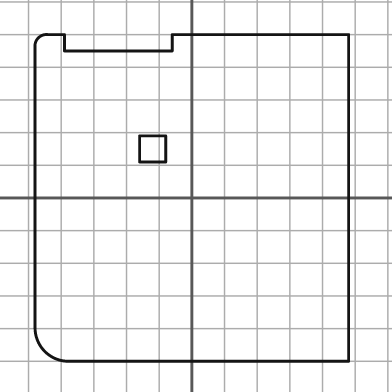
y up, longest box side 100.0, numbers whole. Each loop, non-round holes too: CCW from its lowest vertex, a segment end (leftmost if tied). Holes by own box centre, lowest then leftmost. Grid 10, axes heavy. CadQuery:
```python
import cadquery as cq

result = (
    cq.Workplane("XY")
    .moveTo(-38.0, -50.0)
    .lineTo(48.0, -50.0)
    .lineTo(48.0, 50.0)
    .lineTo(-6.0, 50.0)
    .lineTo(-6.0, 45.0)
    .lineTo(-39.0, 45.0)
    .lineTo(-39.0, 50.0)
    .lineTo(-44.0, 50.0)
    .threePointArc((-47.0, 49.0), (-48.0, 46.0))
    .lineTo(-48.0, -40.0)
    .threePointArc((-45.0, -47.0), (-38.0, -50.0))
    .close()
    .moveTo(-16.0, 11.0)
    .lineTo(-8.0, 11.0)
    .lineTo(-8.0, 19.0)
    .lineTo(-16.0, 19.0)
    .close()
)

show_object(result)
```